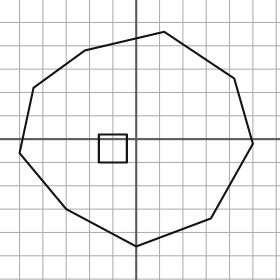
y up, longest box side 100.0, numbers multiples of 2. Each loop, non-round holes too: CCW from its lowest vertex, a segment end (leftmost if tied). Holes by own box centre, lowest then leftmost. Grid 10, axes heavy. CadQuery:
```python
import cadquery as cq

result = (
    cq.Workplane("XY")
    .moveTo(0.0, -46.0)
    .lineTo(32.0, -34.0)
    .lineTo(50.0, -2.0)
    .lineTo(42.0, 26.0)
    .lineTo(12.0, 46.0)
    .lineTo(-22.0, 38.0)
    .lineTo(-44.0, 22.0)
    .lineTo(-50.0, -6.0)
    .lineTo(-30.0, -30.0)
    .close()
    .moveTo(-16.0, -10.0)
    .lineTo(-4.0, -10.0)
    .lineTo(-4.0, 2.0)
    .lineTo(-16.0, 2.0)
    .close()
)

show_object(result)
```